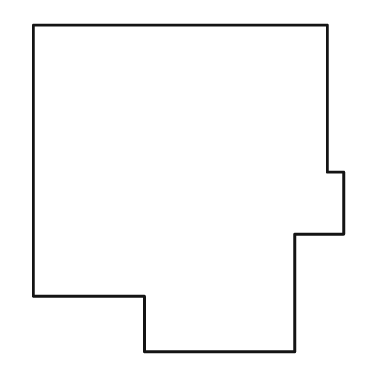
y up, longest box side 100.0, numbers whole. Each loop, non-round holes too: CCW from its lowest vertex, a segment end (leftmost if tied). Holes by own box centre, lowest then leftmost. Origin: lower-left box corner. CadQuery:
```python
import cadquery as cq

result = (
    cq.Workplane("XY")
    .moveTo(34.0, 0.0)
    .lineTo(80.0, 0.0)
    .lineTo(80.0, 36.0)
    .lineTo(95.0, 36.0)
    .lineTo(95.0, 55.0)
    .lineTo(90.0, 55.0)
    .lineTo(90.0, 100.0)
    .lineTo(0.0, 100.0)
    .lineTo(0.0, 17.0)
    .lineTo(34.0, 17.0)
    .close()
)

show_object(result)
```